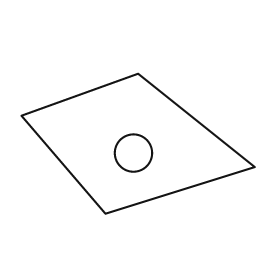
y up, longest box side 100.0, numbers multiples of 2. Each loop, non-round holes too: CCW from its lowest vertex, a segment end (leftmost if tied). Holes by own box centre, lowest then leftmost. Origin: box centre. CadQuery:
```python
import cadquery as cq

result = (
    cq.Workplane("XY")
    .moveTo(-14.0, -30.0)
    .lineTo(50.0, -10.0)
    .lineTo(0.0, 30.0)
    .lineTo(-50.0, 12.0)
    .close()
    .moveTo(-2.0, -4.0)
    .circle(8.0)
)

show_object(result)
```